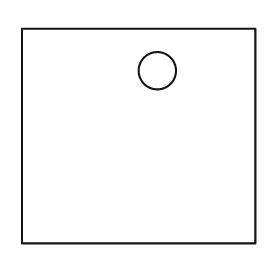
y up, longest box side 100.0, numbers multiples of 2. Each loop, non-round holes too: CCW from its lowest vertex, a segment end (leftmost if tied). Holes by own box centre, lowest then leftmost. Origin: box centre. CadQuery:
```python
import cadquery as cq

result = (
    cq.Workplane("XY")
    .moveTo(-50.0, -46.0)
    .lineTo(50.0, -46.0)
    .lineTo(50.0, 46.0)
    .lineTo(-50.0, 46.0)
    .close()
    .moveTo(8.0, 28.0)
    .circle(8.0)
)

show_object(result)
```